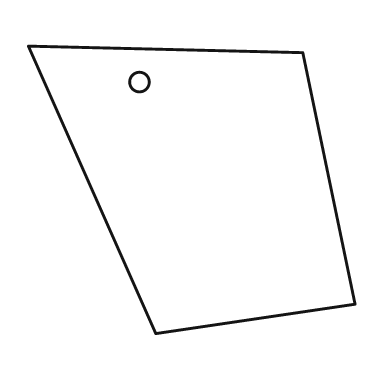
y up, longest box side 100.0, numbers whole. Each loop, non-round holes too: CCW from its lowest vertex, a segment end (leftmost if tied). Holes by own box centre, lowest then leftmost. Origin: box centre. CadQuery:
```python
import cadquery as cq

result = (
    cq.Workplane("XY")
    .moveTo(-11.0, -44.0)
    .lineTo(50.0, -35.0)
    .lineTo(34.0, 42.0)
    .lineTo(-50.0, 44.0)
    .close()
    .moveTo(-16.0, 33.0)
    .circle(3.0)
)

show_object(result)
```